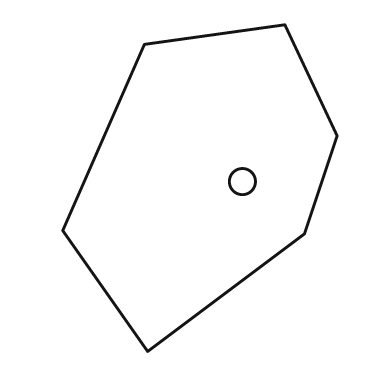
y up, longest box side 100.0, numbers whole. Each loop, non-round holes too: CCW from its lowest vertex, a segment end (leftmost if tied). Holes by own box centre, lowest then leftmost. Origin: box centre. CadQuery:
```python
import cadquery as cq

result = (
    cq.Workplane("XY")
    .moveTo(-16.0, -50.0)
    .lineTo(32.0, -14.0)
    .lineTo(42.0, 16.0)
    .lineTo(26.0, 50.0)
    .lineTo(-17.0, 44.0)
    .lineTo(-42.0, -13.0)
    .close()
    .moveTo(13.0, 2.0)
    .circle(4.0)
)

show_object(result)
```